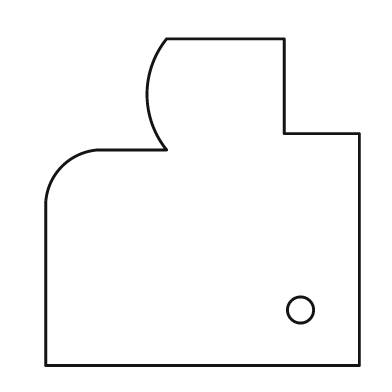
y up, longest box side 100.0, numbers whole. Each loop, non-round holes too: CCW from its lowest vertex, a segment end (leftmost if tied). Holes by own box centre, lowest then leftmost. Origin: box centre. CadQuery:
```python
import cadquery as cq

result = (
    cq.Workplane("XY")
    .moveTo(-48.0, -50.0)
    .lineTo(48.0, -50.0)
    .lineTo(48.0, 21.0)
    .lineTo(25.0, 21.0)
    .lineTo(25.0, 50.0)
    .lineTo(-11.0, 50.0)
    .threePointArc((-17.0, 33.0), (-11.0, 16.0))
    .lineTo(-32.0, 16.0)
    .threePointArc((-43.0, 11.0), (-48.0, 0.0))
    .close()
    .moveTo(30.0, -33.0)
    .circle(4.0)
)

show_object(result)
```